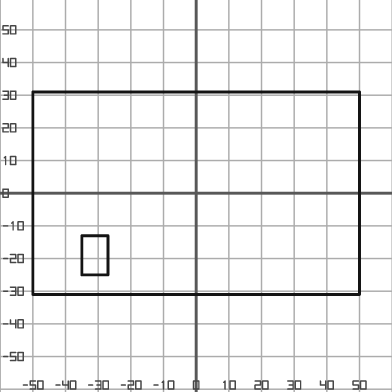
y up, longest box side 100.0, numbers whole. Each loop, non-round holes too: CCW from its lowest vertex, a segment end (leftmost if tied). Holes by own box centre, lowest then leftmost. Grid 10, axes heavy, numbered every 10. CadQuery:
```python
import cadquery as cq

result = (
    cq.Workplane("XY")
    .moveTo(-50.0, -31.0)
    .lineTo(50.0, -31.0)
    .lineTo(50.0, 31.0)
    .lineTo(-50.0, 31.0)
    .close()
    .moveTo(-35.0, -25.0)
    .lineTo(-27.0, -25.0)
    .lineTo(-27.0, -13.0)
    .lineTo(-35.0, -13.0)
    .close()
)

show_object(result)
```